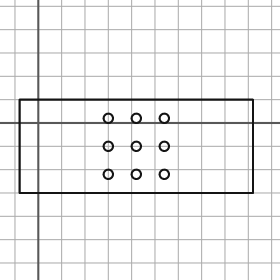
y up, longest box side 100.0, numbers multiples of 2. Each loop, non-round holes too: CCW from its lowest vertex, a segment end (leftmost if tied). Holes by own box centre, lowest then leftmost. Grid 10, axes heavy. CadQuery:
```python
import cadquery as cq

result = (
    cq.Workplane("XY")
    .moveTo(-8.0, -30.0)
    .lineTo(92.0, -30.0)
    .lineTo(92.0, 10.0)
    .lineTo(-8.0, 10.0)
    .close()
    .moveTo(30.0, -22.0)
    .circle(2.0)
    .moveTo(42.0, -22.0)
    .circle(2.0)
    .moveTo(54.0, -22.0)
    .circle(2.0)
    .moveTo(30.0, -10.0)
    .circle(2.0)
    .moveTo(42.0, -10.0)
    .circle(2.0)
    .moveTo(54.0, -10.0)
    .circle(2.0)
    .moveTo(30.0, 2.0)
    .circle(2.0)
    .moveTo(42.0, 2.0)
    .circle(2.0)
    .moveTo(54.0, 2.0)
    .circle(2.0)
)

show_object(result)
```